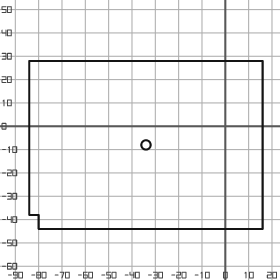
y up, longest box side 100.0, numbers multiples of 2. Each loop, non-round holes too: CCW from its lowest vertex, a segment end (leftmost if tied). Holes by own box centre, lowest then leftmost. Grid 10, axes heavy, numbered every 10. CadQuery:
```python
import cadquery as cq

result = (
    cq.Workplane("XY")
    .moveTo(-80.0, -44.0)
    .lineTo(16.0, -44.0)
    .lineTo(16.0, 28.0)
    .lineTo(-84.0, 28.0)
    .lineTo(-84.0, -38.0)
    .lineTo(-80.0, -38.0)
    .close()
    .moveTo(-34.0, -8.0)
    .circle(2.0)
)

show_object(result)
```